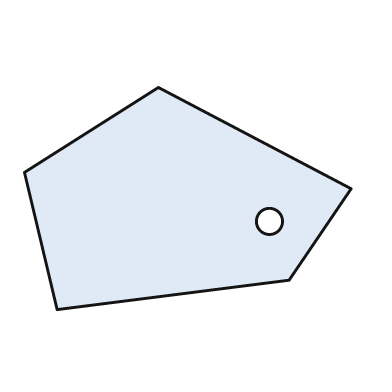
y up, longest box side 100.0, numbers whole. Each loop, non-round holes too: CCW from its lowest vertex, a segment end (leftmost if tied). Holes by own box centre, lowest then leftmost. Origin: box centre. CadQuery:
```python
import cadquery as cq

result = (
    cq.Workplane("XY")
    .moveTo(-40.0, -34.0)
    .lineTo(31.0, -25.0)
    .lineTo(50.0, 3.0)
    .lineTo(-9.0, 34.0)
    .lineTo(-50.0, 8.0)
    .close()
    .moveTo(25.0, -7.0)
    .circle(4.0)
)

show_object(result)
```